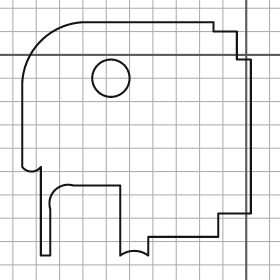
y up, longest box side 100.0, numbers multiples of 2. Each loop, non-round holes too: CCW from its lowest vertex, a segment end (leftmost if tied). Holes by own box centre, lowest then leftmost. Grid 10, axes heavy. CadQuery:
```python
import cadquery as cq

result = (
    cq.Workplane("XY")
    .moveTo(-88.0, -86.0)
    .lineTo(-84.0, -86.0)
    .lineTo(-84.0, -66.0)
    .threePointArc((-82.0, -58.0), (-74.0, -56.0))
    .lineTo(-54.0, -56.0)
    .lineTo(-54.0, -86.0)
    .threePointArc((-48.0, -84.0), (-42.0, -86.0))
    .lineTo(-42.0, -78.0)
    .lineTo(-12.0, -78.0)
    .lineTo(-12.0, -68.0)
    .lineTo(2.0, -68.0)
    .lineTo(2.0, -2.0)
    .lineTo(-4.0, -2.0)
    .lineTo(-4.0, 10.0)
    .lineTo(-14.0, 10.0)
    .lineTo(-14.0, 14.0)
    .lineTo(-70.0, 14.0)
    .threePointArc((-88.0, 6.0), (-96.0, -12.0))
    .lineTo(-96.0, -48.0)
    .threePointArc((-92.0, -50.0), (-88.0, -48.0))
    .close()
    .moveTo(-58.0, -10.0)
    .circle(8.0)
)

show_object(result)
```